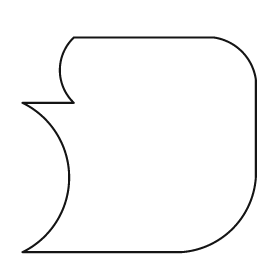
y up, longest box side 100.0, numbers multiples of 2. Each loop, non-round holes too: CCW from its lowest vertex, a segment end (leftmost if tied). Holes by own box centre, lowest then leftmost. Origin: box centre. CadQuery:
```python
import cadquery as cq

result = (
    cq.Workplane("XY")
    .moveTo(-50.0, -46.0)
    .lineTo(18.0, -46.0)
    .threePointArc((40.0, -36.0), (50.0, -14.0))
    .lineTo(50.0, 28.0)
    .threePointArc((44.0, 40.0), (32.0, 46.0))
    .lineTo(-28.0, 46.0)
    .threePointArc((-34.0, 32.0), (-28.0, 18.0))
    .lineTo(-50.0, 18.0)
    .threePointArc((-30.0, -14.0), (-50.0, -46.0))
    .close()
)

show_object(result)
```